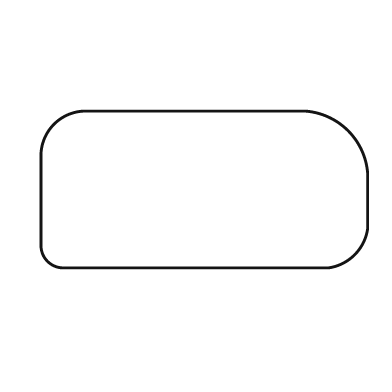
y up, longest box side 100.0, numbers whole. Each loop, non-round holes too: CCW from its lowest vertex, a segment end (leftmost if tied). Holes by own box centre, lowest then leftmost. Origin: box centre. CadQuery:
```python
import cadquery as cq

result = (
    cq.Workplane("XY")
    .moveTo(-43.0, -24.0)
    .lineTo(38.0, -24.0)
    .threePointArc((46.0, -20.0), (50.0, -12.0))
    .lineTo(50.0, 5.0)
    .threePointArc((44.0, 18.0), (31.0, 24.0))
    .lineTo(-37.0, 24.0)
    .threePointArc((-46.0, 20.0), (-50.0, 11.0))
    .lineTo(-50.0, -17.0)
    .threePointArc((-48.0, -22.0), (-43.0, -24.0))
    .close()
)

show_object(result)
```